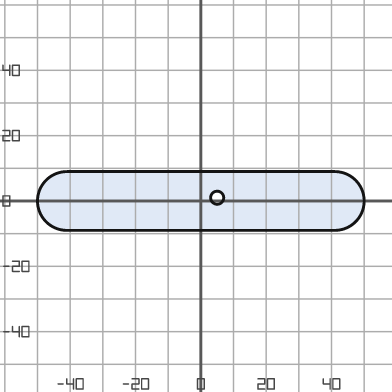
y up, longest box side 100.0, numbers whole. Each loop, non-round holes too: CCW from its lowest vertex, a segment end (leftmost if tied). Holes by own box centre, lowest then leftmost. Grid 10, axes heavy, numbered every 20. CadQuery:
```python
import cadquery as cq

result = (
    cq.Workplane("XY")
    .moveTo(-41.0, -9.0)
    .lineTo(41.0, -9.0)
    .threePointArc((50.0, 0.0), (41.0, 9.0))
    .lineTo(-41.0, 9.0)
    .threePointArc((-50.0, 0.0), (-41.0, -9.0))
    .close()
    .moveTo(5.0, 1.0)
    .circle(2.0)
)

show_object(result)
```